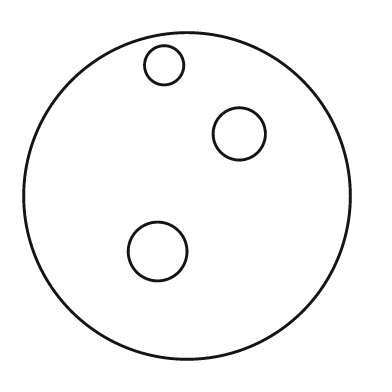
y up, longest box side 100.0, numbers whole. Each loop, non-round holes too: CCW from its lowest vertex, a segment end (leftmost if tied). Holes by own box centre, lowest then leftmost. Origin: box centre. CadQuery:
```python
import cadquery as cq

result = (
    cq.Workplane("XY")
    .moveTo(0.0, 0.0)
    .circle(50.0)
    .moveTo(-9.0, -17.0)
    .circle(9.0)
    .moveTo(16.0, 19.0)
    .circle(8.0)
    .moveTo(-7.0, 40.0)
    .circle(6.0)
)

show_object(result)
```